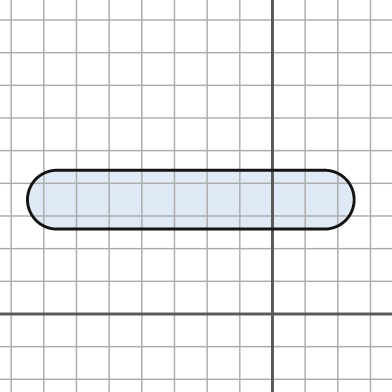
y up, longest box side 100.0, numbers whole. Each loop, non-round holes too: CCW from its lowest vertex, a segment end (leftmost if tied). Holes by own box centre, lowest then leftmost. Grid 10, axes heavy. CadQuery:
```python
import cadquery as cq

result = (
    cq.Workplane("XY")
    .moveTo(-66.0, 26.0)
    .lineTo(16.0, 26.0)
    .threePointArc((25.0, 35.0), (16.0, 44.0))
    .lineTo(-66.0, 44.0)
    .threePointArc((-75.0, 35.0), (-66.0, 26.0))
    .close()
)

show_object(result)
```